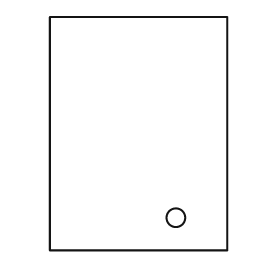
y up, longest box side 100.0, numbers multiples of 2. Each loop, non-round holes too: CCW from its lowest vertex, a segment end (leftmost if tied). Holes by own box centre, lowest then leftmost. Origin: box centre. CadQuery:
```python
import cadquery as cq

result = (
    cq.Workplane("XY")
    .moveTo(-38.0, -50.0)
    .lineTo(38.0, -50.0)
    .lineTo(38.0, 50.0)
    .lineTo(-38.0, 50.0)
    .close()
    .moveTo(16.0, -36.0)
    .circle(4.0)
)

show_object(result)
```